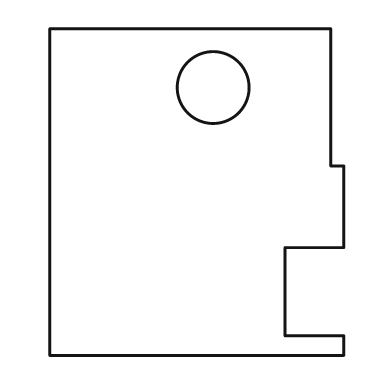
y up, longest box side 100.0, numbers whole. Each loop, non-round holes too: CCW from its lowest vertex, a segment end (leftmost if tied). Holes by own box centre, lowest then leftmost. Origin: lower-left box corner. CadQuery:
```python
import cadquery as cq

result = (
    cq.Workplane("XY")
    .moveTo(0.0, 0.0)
    .lineTo(90.0, 0.0)
    .lineTo(90.0, 6.0)
    .lineTo(72.0, 6.0)
    .lineTo(72.0, 33.0)
    .lineTo(90.0, 33.0)
    .lineTo(90.0, 58.0)
    .lineTo(86.0, 58.0)
    .lineTo(86.0, 100.0)
    .lineTo(0.0, 100.0)
    .close()
    .moveTo(50.0, 82.0)
    .circle(11.0)
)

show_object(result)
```